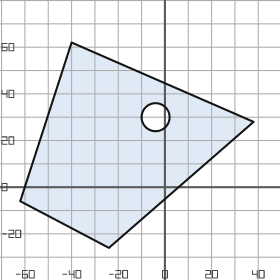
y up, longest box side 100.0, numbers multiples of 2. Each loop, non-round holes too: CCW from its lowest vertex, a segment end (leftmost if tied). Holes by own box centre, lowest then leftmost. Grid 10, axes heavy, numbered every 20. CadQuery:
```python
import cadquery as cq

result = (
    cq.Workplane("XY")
    .moveTo(-24.0, -26.0)
    .lineTo(38.0, 28.0)
    .lineTo(-40.0, 62.0)
    .lineTo(-62.0, -6.0)
    .close()
    .moveTo(-4.0, 30.0)
    .circle(6.0)
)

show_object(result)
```